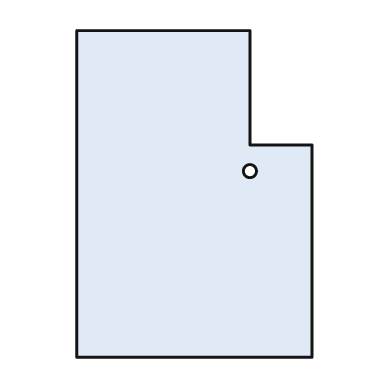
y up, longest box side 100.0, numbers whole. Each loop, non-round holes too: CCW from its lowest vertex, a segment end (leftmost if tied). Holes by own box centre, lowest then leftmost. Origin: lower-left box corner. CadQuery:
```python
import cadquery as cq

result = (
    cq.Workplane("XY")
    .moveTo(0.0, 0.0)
    .lineTo(72.0, 0.0)
    .lineTo(72.0, 65.0)
    .lineTo(53.0, 65.0)
    .lineTo(53.0, 100.0)
    .lineTo(0.0, 100.0)
    .close()
    .moveTo(53.0, 57.0)
    .circle(2.0)
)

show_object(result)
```